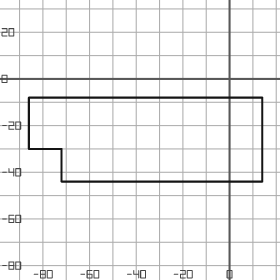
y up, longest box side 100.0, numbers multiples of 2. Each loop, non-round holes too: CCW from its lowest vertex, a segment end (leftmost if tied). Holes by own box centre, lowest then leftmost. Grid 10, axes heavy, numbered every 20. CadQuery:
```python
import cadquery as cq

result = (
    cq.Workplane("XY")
    .moveTo(-72.0, -44.0)
    .lineTo(14.0, -44.0)
    .lineTo(14.0, -8.0)
    .lineTo(-86.0, -8.0)
    .lineTo(-86.0, -30.0)
    .lineTo(-72.0, -30.0)
    .close()
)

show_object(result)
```